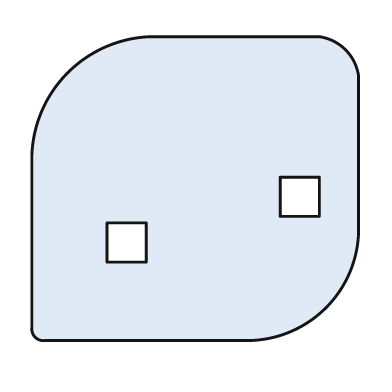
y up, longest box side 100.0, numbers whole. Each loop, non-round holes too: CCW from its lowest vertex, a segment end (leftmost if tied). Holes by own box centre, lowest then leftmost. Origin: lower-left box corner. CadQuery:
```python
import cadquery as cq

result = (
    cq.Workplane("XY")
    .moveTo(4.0, 0.0)
    .lineTo(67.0, 0.0)
    .threePointArc((90.0, 10.0), (100.0, 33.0))
    .lineTo(100.0, 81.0)
    .threePointArc((96.0, 89.0), (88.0, 93.0))
    .lineTo(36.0, 93.0)
    .threePointArc((11.0, 82.0), (0.0, 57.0))
    .lineTo(0.0, 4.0)
    .threePointArc((1.0, 1.0), (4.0, 0.0))
    .close()
    .moveTo(23.0, 24.0)
    .lineTo(35.0, 24.0)
    .lineTo(35.0, 36.0)
    .lineTo(23.0, 36.0)
    .close()
    .moveTo(76.0, 38.0)
    .lineTo(88.0, 38.0)
    .lineTo(88.0, 50.0)
    .lineTo(76.0, 50.0)
    .close()
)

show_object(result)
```